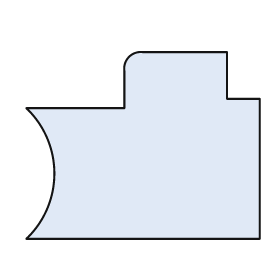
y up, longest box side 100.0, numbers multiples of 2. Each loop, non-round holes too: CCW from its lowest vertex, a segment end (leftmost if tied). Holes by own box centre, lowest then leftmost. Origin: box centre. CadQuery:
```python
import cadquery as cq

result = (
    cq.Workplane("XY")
    .moveTo(-50.0, -40.0)
    .lineTo(50.0, -40.0)
    .lineTo(50.0, 20.0)
    .lineTo(36.0, 20.0)
    .lineTo(36.0, 40.0)
    .lineTo(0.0, 40.0)
    .threePointArc((-6.0, 38.0), (-8.0, 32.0))
    .lineTo(-8.0, 16.0)
    .lineTo(-50.0, 16.0)
    .threePointArc((-38.0, -12.0), (-50.0, -40.0))
    .close()
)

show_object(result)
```